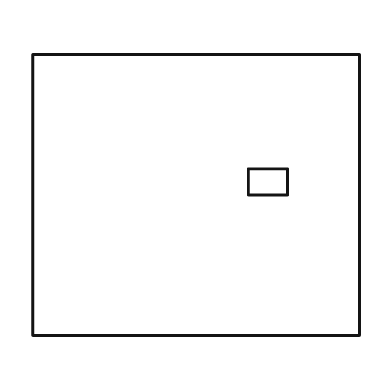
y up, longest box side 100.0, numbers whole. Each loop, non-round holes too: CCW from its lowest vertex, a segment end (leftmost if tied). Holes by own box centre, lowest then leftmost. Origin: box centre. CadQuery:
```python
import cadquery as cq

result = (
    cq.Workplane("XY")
    .moveTo(-50.0, -43.0)
    .lineTo(50.0, -43.0)
    .lineTo(50.0, 43.0)
    .lineTo(-50.0, 43.0)
    .close()
    .moveTo(16.0, 0.0)
    .lineTo(28.0, 0.0)
    .lineTo(28.0, 8.0)
    .lineTo(16.0, 8.0)
    .close()
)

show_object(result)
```